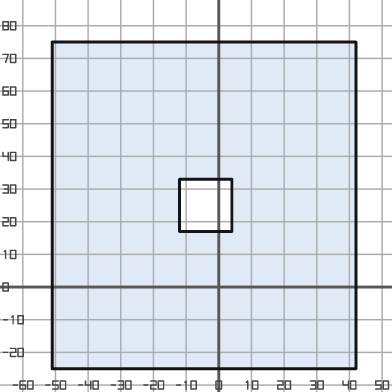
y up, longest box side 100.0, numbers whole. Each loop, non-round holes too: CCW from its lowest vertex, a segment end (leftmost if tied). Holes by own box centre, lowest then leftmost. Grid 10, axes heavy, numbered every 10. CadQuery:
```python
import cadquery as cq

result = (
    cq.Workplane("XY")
    .moveTo(-51.0, -25.0)
    .lineTo(42.0, -25.0)
    .lineTo(42.0, 75.0)
    .lineTo(-51.0, 75.0)
    .close()
    .moveTo(-12.0, 17.0)
    .lineTo(4.0, 17.0)
    .lineTo(4.0, 33.0)
    .lineTo(-12.0, 33.0)
    .close()
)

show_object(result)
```